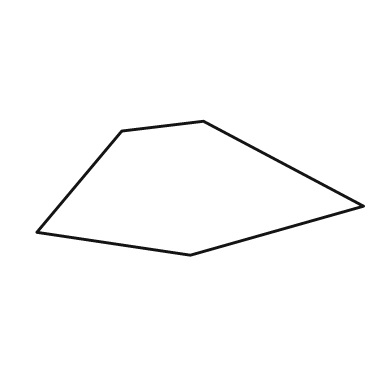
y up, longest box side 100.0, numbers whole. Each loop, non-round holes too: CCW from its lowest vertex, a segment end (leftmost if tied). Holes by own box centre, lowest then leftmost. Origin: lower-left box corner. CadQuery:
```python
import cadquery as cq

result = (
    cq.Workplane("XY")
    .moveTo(47.0, 0.0)
    .lineTo(100.0, 15.0)
    .lineTo(51.0, 41.0)
    .lineTo(26.0, 38.0)
    .lineTo(0.0, 7.0)
    .close()
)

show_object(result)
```